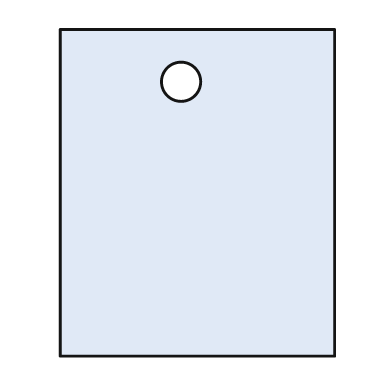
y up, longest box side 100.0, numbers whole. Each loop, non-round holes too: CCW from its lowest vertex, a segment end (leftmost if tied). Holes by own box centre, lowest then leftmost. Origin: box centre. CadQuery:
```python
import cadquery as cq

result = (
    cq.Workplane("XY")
    .moveTo(-42.0, -50.0)
    .lineTo(42.0, -50.0)
    .lineTo(42.0, 50.0)
    .lineTo(-42.0, 50.0)
    .close()
    .moveTo(-5.0, 34.0)
    .circle(6.0)
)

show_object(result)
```